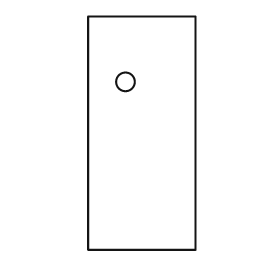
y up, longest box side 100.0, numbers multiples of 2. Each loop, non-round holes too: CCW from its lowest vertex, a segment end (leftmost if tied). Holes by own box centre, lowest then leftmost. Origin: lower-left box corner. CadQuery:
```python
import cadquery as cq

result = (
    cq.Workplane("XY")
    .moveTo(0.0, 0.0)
    .lineTo(46.0, 0.0)
    .lineTo(46.0, 100.0)
    .lineTo(0.0, 100.0)
    .close()
    .moveTo(16.0, 72.0)
    .circle(4.0)
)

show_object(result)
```